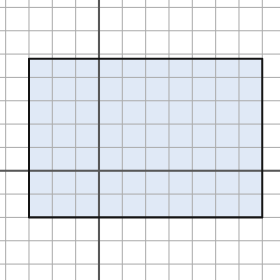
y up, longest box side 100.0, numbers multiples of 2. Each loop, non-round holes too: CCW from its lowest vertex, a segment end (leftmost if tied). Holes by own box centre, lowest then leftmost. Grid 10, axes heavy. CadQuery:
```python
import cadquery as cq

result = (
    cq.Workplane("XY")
    .moveTo(-30.0, -20.0)
    .lineTo(70.0, -20.0)
    .lineTo(70.0, 48.0)
    .lineTo(-30.0, 48.0)
    .close()
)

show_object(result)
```